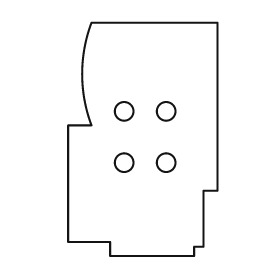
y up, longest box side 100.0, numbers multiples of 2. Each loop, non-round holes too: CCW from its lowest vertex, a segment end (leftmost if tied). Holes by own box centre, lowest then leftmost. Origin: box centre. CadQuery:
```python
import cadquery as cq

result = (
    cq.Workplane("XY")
    .moveTo(-14.0, -50.0)
    .lineTo(22.0, -50.0)
    .lineTo(22.0, -46.0)
    .lineTo(26.0, -46.0)
    .lineTo(26.0, -22.0)
    .lineTo(32.0, -22.0)
    .lineTo(32.0, 50.0)
    .lineTo(-22.0, 50.0)
    .threePointArc((-26.0, 28.0), (-22.0, 6.0))
    .lineTo(-32.0, 6.0)
    .lineTo(-32.0, -44.0)
    .lineTo(-14.0, -44.0)
    .close()
    .moveTo(-8.0, -10.0)
    .circle(4.0)
    .moveTo(10.0, -10.0)
    .circle(4.0)
    .moveTo(-8.0, 12.0)
    .circle(4.0)
    .moveTo(10.0, 12.0)
    .circle(4.0)
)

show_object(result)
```